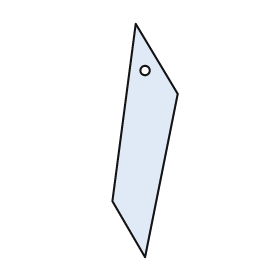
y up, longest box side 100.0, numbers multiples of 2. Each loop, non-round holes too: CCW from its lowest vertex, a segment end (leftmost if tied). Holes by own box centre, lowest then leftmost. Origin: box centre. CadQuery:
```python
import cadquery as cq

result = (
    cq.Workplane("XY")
    .moveTo(0.0, -50.0)
    .lineTo(14.0, 20.0)
    .lineTo(-4.0, 50.0)
    .lineTo(-14.0, -26.0)
    .close()
    .moveTo(0.0, 30.0)
    .circle(2.0)
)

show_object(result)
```